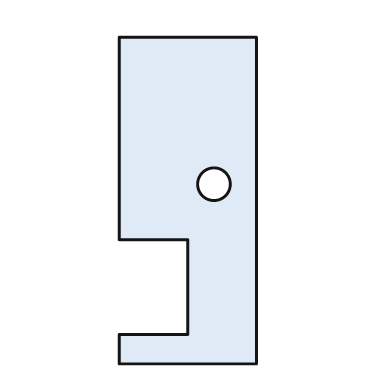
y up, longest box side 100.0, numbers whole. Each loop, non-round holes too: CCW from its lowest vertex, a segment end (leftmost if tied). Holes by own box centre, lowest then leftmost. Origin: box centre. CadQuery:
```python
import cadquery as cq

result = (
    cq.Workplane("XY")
    .moveTo(-21.0, -50.0)
    .lineTo(21.0, -50.0)
    .lineTo(21.0, 50.0)
    .lineTo(-21.0, 50.0)
    .lineTo(-21.0, -12.0)
    .lineTo(0.0, -12.0)
    .lineTo(0.0, -41.0)
    .lineTo(-21.0, -41.0)
    .close()
    .moveTo(8.0, 5.0)
    .circle(5.0)
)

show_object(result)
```